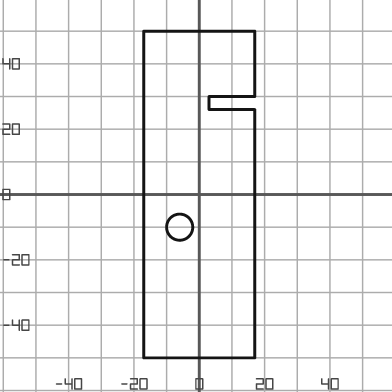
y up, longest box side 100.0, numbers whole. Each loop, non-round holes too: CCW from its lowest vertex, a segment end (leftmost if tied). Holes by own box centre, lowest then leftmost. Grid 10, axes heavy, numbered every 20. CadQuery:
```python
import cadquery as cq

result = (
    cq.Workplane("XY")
    .moveTo(-17.0, -50.0)
    .lineTo(17.0, -50.0)
    .lineTo(17.0, 26.0)
    .lineTo(3.0, 26.0)
    .lineTo(3.0, 30.0)
    .lineTo(17.0, 30.0)
    .lineTo(17.0, 50.0)
    .lineTo(-17.0, 50.0)
    .close()
    .moveTo(-6.0, -10.0)
    .circle(4.0)
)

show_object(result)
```